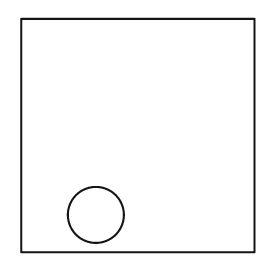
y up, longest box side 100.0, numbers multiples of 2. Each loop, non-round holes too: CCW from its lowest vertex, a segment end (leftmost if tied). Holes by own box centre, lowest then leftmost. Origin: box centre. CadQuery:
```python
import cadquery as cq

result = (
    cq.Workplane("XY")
    .moveTo(-50.0, -50.0)
    .lineTo(50.0, -50.0)
    .lineTo(50.0, 50.0)
    .lineTo(-50.0, 50.0)
    .close()
    .moveTo(-18.0, -34.0)
    .circle(12.0)
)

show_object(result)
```